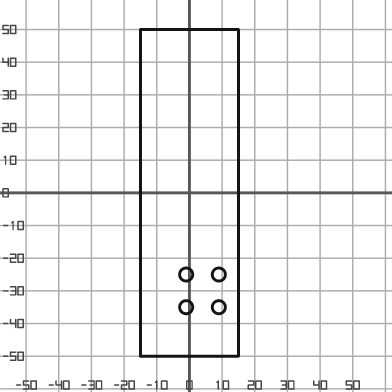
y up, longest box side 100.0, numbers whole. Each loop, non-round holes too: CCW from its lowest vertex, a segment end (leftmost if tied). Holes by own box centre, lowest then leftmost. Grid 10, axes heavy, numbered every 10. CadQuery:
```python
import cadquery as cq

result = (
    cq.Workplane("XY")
    .moveTo(-15.0, -50.0)
    .lineTo(15.0, -50.0)
    .lineTo(15.0, 50.0)
    .lineTo(-15.0, 50.0)
    .close()
    .moveTo(-1.0, -35.0)
    .circle(2.0)
    .moveTo(9.0, -35.0)
    .circle(2.0)
    .moveTo(-1.0, -25.0)
    .circle(2.0)
    .moveTo(9.0, -25.0)
    .circle(2.0)
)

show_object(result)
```